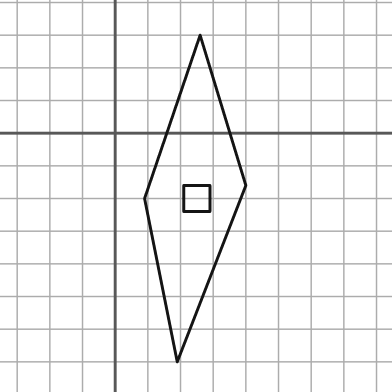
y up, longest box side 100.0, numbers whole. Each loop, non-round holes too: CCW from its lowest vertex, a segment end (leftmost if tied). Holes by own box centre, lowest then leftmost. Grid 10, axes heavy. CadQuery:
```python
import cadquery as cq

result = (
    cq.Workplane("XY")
    .moveTo(19.0, -70.0)
    .lineTo(40.0, -16.0)
    .lineTo(26.0, 30.0)
    .lineTo(9.0, -20.0)
    .close()
    .moveTo(21.0, -24.0)
    .lineTo(29.0, -24.0)
    .lineTo(29.0, -16.0)
    .lineTo(21.0, -16.0)
    .close()
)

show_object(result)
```